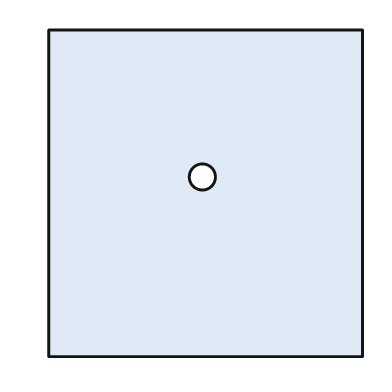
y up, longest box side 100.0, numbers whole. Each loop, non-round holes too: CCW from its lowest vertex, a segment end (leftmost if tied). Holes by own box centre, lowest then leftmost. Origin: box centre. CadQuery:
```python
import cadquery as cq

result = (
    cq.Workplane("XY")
    .moveTo(-48.0, -50.0)
    .lineTo(48.0, -50.0)
    .lineTo(48.0, 50.0)
    .lineTo(-48.0, 50.0)
    .close()
    .moveTo(-1.0, 5.0)
    .circle(4.0)
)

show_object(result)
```